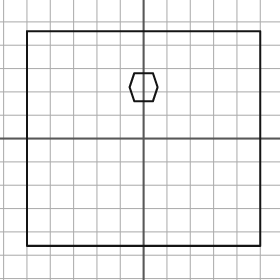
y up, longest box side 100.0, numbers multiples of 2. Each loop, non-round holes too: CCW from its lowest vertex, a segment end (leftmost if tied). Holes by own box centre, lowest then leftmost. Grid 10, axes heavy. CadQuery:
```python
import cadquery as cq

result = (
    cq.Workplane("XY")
    .moveTo(-50.0, -46.0)
    .lineTo(50.0, -46.0)
    .lineTo(50.0, 46.0)
    .lineTo(-50.0, 46.0)
    .close()
    .moveTo(-4.0, 16.0)
    .lineTo(4.0, 16.0)
    .lineTo(6.0, 22.0)
    .lineTo(4.0, 28.0)
    .lineTo(-4.0, 28.0)
    .lineTo(-6.0, 22.0)
    .close()
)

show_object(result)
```